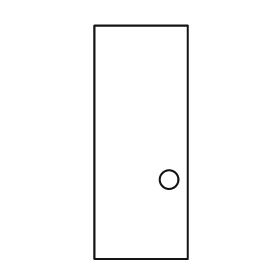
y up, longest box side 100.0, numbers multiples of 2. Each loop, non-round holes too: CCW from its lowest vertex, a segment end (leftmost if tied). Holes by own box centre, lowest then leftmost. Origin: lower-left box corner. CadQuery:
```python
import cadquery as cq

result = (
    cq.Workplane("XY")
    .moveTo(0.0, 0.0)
    .lineTo(40.0, 0.0)
    .lineTo(40.0, 100.0)
    .lineTo(0.0, 100.0)
    .close()
    .moveTo(32.0, 34.0)
    .circle(4.0)
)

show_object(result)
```